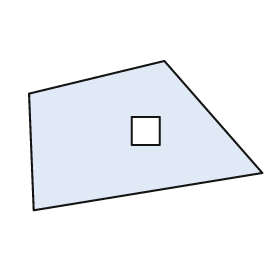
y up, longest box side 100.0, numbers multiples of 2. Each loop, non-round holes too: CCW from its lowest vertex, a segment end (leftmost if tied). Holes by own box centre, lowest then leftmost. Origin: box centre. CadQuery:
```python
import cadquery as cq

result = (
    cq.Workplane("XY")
    .moveTo(-48.0, -32.0)
    .lineTo(50.0, -16.0)
    .lineTo(8.0, 32.0)
    .lineTo(-50.0, 18.0)
    .close()
    .moveTo(-6.0, -4.0)
    .lineTo(6.0, -4.0)
    .lineTo(6.0, 8.0)
    .lineTo(-6.0, 8.0)
    .close()
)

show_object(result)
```